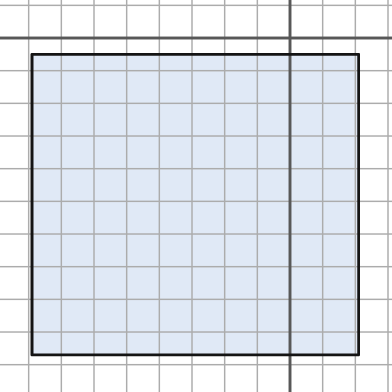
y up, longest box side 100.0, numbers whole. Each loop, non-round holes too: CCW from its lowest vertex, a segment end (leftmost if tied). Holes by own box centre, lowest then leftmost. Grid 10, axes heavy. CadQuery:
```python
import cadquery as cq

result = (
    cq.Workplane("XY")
    .moveTo(-79.0, -97.0)
    .lineTo(21.0, -97.0)
    .lineTo(21.0, -5.0)
    .lineTo(-79.0, -5.0)
    .close()
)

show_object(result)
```